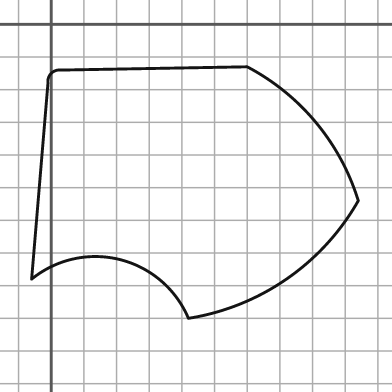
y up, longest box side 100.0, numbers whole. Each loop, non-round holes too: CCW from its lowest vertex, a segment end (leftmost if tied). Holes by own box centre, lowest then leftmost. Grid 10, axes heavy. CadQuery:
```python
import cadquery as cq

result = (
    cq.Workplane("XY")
    .moveTo(42.0, -90.0)
    .threePointArc((72.0, -78.0), (94.0, -54.0))
    .threePointArc((81.0, -30.0), (60.0, -13.0))
    .lineTo(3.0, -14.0)
    .threePointArc((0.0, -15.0), (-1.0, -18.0))
    .lineTo(-6.0, -78.0)
    .threePointArc((21.0, -72.0), (42.0, -90.0))
    .close()
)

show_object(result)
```